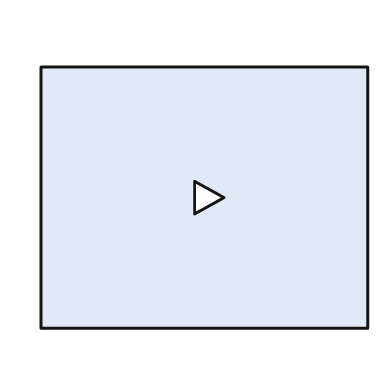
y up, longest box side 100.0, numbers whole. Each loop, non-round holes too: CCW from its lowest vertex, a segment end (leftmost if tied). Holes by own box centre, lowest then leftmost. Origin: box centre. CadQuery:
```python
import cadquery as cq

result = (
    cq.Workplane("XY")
    .moveTo(-50.0, -40.0)
    .lineTo(50.0, -40.0)
    .lineTo(50.0, 40.0)
    .lineTo(-50.0, 40.0)
    .close()
    .moveTo(-3.0, -5.0)
    .lineTo(6.0, 0.0)
    .lineTo(-3.0, 5.0)
    .close()
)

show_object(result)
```